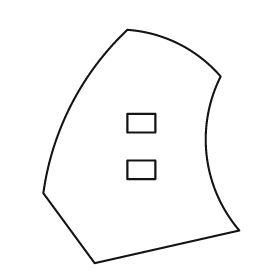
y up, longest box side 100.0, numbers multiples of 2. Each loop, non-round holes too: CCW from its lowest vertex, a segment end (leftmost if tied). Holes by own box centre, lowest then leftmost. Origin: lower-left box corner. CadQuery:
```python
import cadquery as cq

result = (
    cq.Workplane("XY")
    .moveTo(22.0, 0.0)
    .lineTo(84.0, 14.0)
    .threePointArc((70.0, 46.0), (76.0, 80.0))
    .threePointArc((58.0, 94.0), (36.0, 100.0))
    .threePointArc((12.0, 68.0), (0.0, 30.0))
    .close()
    .moveTo(36.0, 36.0)
    .lineTo(48.0, 36.0)
    .lineTo(48.0, 44.0)
    .lineTo(36.0, 44.0)
    .close()
    .moveTo(36.0, 56.0)
    .lineTo(48.0, 56.0)
    .lineTo(48.0, 64.0)
    .lineTo(36.0, 64.0)
    .close()
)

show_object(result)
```